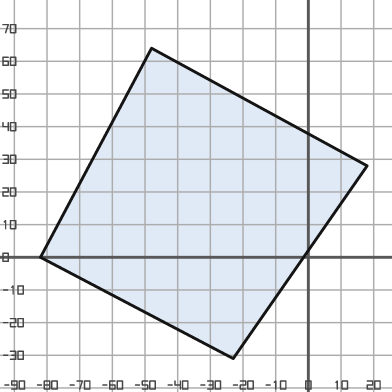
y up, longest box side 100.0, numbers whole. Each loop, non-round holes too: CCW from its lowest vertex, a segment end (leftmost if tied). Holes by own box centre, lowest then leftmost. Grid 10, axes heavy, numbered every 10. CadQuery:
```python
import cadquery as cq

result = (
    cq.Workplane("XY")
    .moveTo(-23.0, -31.0)
    .lineTo(18.0, 28.0)
    .lineTo(-48.0, 64.0)
    .lineTo(-82.0, 0.0)
    .close()
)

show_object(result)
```